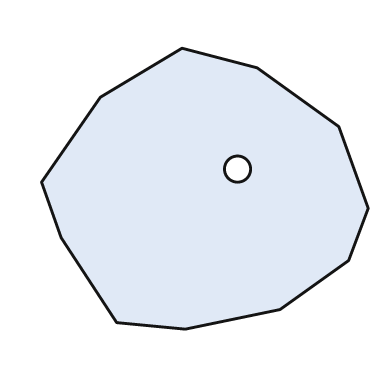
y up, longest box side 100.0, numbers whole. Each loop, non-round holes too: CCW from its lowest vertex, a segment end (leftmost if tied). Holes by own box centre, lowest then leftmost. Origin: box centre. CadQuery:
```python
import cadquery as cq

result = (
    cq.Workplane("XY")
    .moveTo(-6.0, -43.0)
    .lineTo(23.0, -37.0)
    .lineTo(44.0, -22.0)
    .lineTo(50.0, -6.0)
    .lineTo(41.0, 19.0)
    .lineTo(16.0, 37.0)
    .lineTo(-7.0, 43.0)
    .lineTo(-32.0, 28.0)
    .lineTo(-50.0, 2.0)
    .lineTo(-44.0, -15.0)
    .lineTo(-27.0, -41.0)
    .close()
    .moveTo(10.0, 6.0)
    .circle(4.0)
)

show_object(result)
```